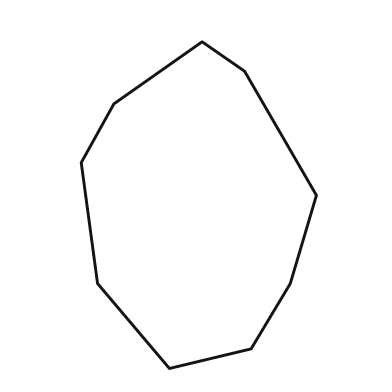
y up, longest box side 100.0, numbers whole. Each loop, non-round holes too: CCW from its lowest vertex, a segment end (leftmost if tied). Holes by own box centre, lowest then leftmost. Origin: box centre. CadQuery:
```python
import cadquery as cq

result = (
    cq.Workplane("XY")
    .moveTo(-9.0, -50.0)
    .lineTo(16.0, -44.0)
    .lineTo(28.0, -24.0)
    .lineTo(36.0, 3.0)
    .lineTo(14.0, 41.0)
    .lineTo(1.0, 50.0)
    .lineTo(-26.0, 31.0)
    .lineTo(-36.0, 13.0)
    .lineTo(-31.0, -24.0)
    .close()
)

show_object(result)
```